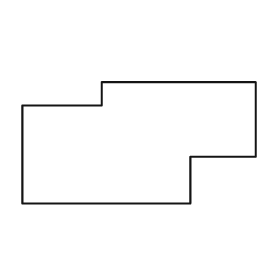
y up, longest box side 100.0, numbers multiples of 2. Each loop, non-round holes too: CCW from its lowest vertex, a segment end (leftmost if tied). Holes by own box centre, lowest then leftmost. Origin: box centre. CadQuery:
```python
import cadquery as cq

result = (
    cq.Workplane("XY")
    .moveTo(-50.0, -26.0)
    .lineTo(22.0, -26.0)
    .lineTo(22.0, -6.0)
    .lineTo(50.0, -6.0)
    .lineTo(50.0, 26.0)
    .lineTo(-16.0, 26.0)
    .lineTo(-16.0, 16.0)
    .lineTo(-50.0, 16.0)
    .close()
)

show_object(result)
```